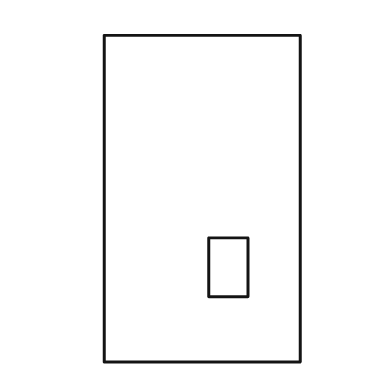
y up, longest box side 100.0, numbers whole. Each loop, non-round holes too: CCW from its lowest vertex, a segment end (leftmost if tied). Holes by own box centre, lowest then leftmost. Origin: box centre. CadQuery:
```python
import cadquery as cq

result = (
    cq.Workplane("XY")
    .moveTo(-30.0, -50.0)
    .lineTo(30.0, -50.0)
    .lineTo(30.0, 50.0)
    .lineTo(-30.0, 50.0)
    .close()
    .moveTo(2.0, -30.0)
    .lineTo(14.0, -30.0)
    .lineTo(14.0, -12.0)
    .lineTo(2.0, -12.0)
    .close()
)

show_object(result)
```